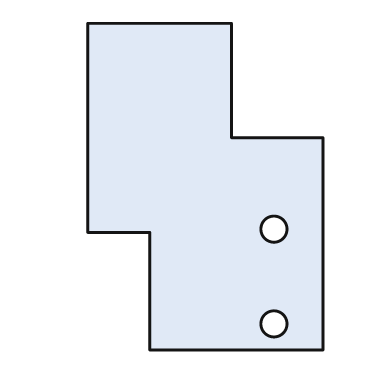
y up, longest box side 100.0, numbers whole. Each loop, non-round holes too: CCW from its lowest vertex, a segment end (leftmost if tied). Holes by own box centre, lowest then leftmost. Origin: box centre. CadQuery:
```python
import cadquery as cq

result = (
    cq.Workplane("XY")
    .moveTo(-17.0, -50.0)
    .lineTo(36.0, -50.0)
    .lineTo(36.0, 15.0)
    .lineTo(8.0, 15.0)
    .lineTo(8.0, 50.0)
    .lineTo(-36.0, 50.0)
    .lineTo(-36.0, -14.0)
    .lineTo(-17.0, -14.0)
    .close()
    .moveTo(21.0, -42.0)
    .circle(4.0)
    .moveTo(21.0, -13.0)
    .circle(4.0)
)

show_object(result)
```